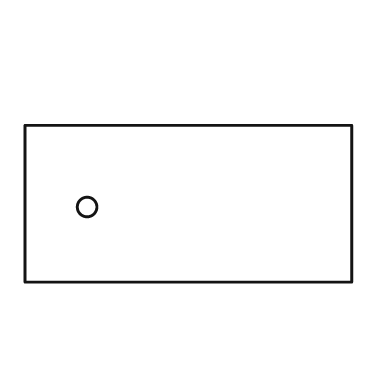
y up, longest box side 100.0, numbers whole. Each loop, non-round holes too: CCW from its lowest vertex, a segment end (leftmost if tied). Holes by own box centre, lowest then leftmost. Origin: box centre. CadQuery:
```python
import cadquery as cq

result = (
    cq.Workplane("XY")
    .moveTo(-50.0, -24.0)
    .lineTo(50.0, -24.0)
    .lineTo(50.0, 24.0)
    .lineTo(-50.0, 24.0)
    .close()
    .moveTo(-31.0, -1.0)
    .circle(3.0)
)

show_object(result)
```